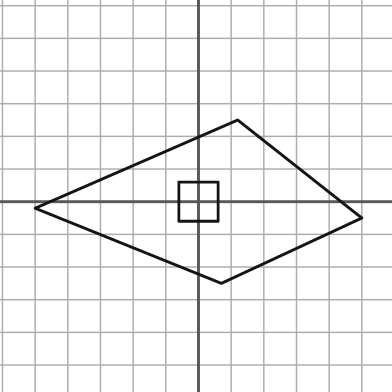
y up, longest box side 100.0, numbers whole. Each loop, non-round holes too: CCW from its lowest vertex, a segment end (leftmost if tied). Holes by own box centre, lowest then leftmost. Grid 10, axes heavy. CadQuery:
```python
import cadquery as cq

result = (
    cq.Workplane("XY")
    .moveTo(7.0, -25.0)
    .lineTo(50.0, -5.0)
    .lineTo(12.0, 25.0)
    .lineTo(-50.0, -2.0)
    .close()
    .moveTo(-6.0, -6.0)
    .lineTo(6.0, -6.0)
    .lineTo(6.0, 6.0)
    .lineTo(-6.0, 6.0)
    .close()
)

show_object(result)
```